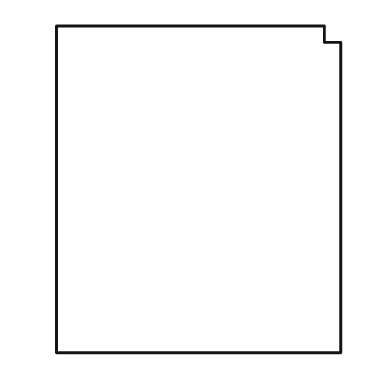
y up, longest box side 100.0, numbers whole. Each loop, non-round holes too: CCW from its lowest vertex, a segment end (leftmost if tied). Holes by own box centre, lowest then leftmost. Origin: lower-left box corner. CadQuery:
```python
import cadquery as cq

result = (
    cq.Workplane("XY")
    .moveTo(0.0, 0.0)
    .lineTo(87.0, 0.0)
    .lineTo(87.0, 95.0)
    .lineTo(82.0, 95.0)
    .lineTo(82.0, 100.0)
    .lineTo(0.0, 100.0)
    .close()
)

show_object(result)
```